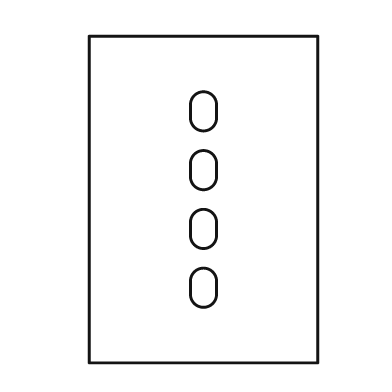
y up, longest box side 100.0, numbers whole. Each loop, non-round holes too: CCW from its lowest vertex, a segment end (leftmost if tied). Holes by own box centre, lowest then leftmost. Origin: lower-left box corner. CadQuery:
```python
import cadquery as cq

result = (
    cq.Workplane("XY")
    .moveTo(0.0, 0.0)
    .lineTo(70.0, 0.0)
    .lineTo(70.0, 100.0)
    .lineTo(0.0, 100.0)
    .close()
    .moveTo(31.0, 21.0)
    .threePointArc((35.0, 17.0), (39.0, 21.0))
    .lineTo(39.0, 25.0)
    .threePointArc((35.0, 29.0), (31.0, 25.0))
    .close()
    .moveTo(31.0, 39.0)
    .threePointArc((35.0, 35.0), (39.0, 39.0))
    .lineTo(39.0, 43.0)
    .threePointArc((35.0, 47.0), (31.0, 43.0))
    .close()
    .moveTo(31.0, 57.0)
    .threePointArc((35.0, 53.0), (39.0, 57.0))
    .lineTo(39.0, 61.0)
    .threePointArc((35.0, 65.0), (31.0, 61.0))
    .close()
    .moveTo(31.0, 75.0)
    .threePointArc((35.0, 71.0), (39.0, 75.0))
    .lineTo(39.0, 79.0)
    .threePointArc((35.0, 83.0), (31.0, 79.0))
    .close()
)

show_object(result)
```